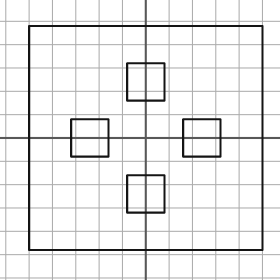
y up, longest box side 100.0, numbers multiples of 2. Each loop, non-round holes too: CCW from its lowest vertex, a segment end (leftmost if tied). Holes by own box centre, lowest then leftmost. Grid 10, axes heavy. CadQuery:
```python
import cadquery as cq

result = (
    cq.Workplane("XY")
    .moveTo(-50.0, -48.0)
    .lineTo(50.0, -48.0)
    .lineTo(50.0, 48.0)
    .lineTo(-50.0, 48.0)
    .close()
    .moveTo(-8.0, -32.0)
    .lineTo(8.0, -32.0)
    .lineTo(8.0, -16.0)
    .lineTo(-8.0, -16.0)
    .close()
    .moveTo(-32.0, -8.0)
    .lineTo(-16.0, -8.0)
    .lineTo(-16.0, 8.0)
    .lineTo(-32.0, 8.0)
    .close()
    .moveTo(16.0, -8.0)
    .lineTo(32.0, -8.0)
    .lineTo(32.0, 8.0)
    .lineTo(16.0, 8.0)
    .close()
    .moveTo(-8.0, 16.0)
    .lineTo(8.0, 16.0)
    .lineTo(8.0, 32.0)
    .lineTo(-8.0, 32.0)
    .close()
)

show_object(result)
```